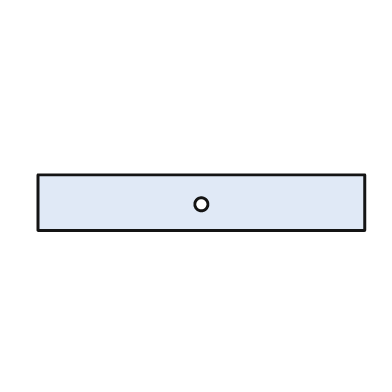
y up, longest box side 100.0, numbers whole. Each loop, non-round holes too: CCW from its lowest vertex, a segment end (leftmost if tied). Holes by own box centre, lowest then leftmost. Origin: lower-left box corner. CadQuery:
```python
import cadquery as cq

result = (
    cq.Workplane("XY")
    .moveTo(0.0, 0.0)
    .lineTo(100.0, 0.0)
    .lineTo(100.0, 17.0)
    .lineTo(0.0, 17.0)
    .close()
    .moveTo(50.0, 8.0)
    .circle(2.0)
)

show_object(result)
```